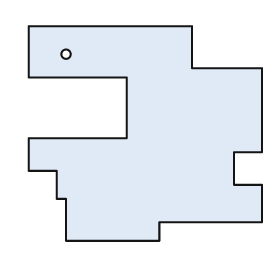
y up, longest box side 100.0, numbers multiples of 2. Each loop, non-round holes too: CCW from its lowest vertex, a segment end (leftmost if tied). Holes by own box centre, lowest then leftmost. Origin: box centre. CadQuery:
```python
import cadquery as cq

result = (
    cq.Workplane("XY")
    .moveTo(-34.0, -46.0)
    .lineTo(6.0, -46.0)
    .lineTo(6.0, -38.0)
    .lineTo(50.0, -38.0)
    .lineTo(50.0, -22.0)
    .lineTo(38.0, -22.0)
    .lineTo(38.0, -8.0)
    .lineTo(50.0, -8.0)
    .lineTo(50.0, 28.0)
    .lineTo(20.0, 28.0)
    .lineTo(20.0, 46.0)
    .lineTo(-50.0, 46.0)
    .lineTo(-50.0, 24.0)
    .lineTo(-8.0, 24.0)
    .lineTo(-8.0, -2.0)
    .lineTo(-50.0, -2.0)
    .lineTo(-50.0, -16.0)
    .lineTo(-38.0, -16.0)
    .lineTo(-38.0, -28.0)
    .lineTo(-34.0, -28.0)
    .close()
    .moveTo(-34.0, 34.0)
    .circle(2.0)
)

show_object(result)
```